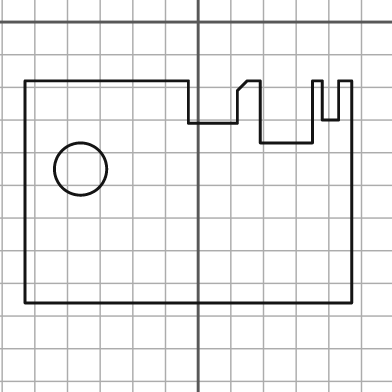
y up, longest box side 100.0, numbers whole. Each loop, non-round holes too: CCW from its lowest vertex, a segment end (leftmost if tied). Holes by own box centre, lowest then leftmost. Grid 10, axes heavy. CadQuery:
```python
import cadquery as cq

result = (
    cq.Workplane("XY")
    .moveTo(-53.0, -86.0)
    .lineTo(47.0, -86.0)
    .lineTo(47.0, -18.0)
    .lineTo(43.0, -18.0)
    .lineTo(43.0, -30.0)
    .lineTo(38.0, -30.0)
    .lineTo(38.0, -18.0)
    .lineTo(35.0, -18.0)
    .lineTo(35.0, -37.0)
    .lineTo(19.0, -37.0)
    .lineTo(19.0, -18.0)
    .lineTo(15.0, -18.0)
    .lineTo(12.0, -21.0)
    .lineTo(12.0, -31.0)
    .lineTo(-3.0, -31.0)
    .lineTo(-3.0, -18.0)
    .lineTo(-53.0, -18.0)
    .close()
    .moveTo(-36.0, -45.0)
    .circle(8.0)
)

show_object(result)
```